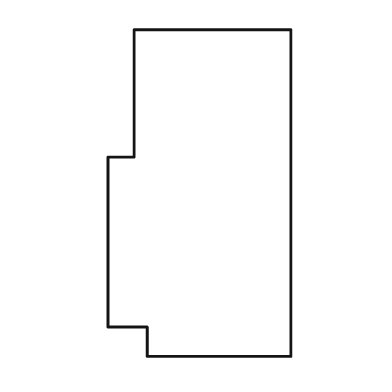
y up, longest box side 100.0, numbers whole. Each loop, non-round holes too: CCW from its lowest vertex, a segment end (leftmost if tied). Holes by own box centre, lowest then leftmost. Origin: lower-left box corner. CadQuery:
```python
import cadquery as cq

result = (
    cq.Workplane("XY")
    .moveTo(12.0, 0.0)
    .lineTo(56.0, 0.0)
    .lineTo(56.0, 100.0)
    .lineTo(8.0, 100.0)
    .lineTo(8.0, 61.0)
    .lineTo(0.0, 61.0)
    .lineTo(0.0, 9.0)
    .lineTo(12.0, 9.0)
    .close()
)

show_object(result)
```